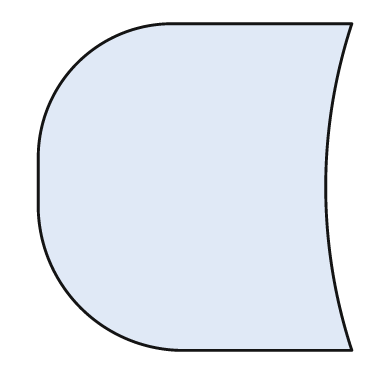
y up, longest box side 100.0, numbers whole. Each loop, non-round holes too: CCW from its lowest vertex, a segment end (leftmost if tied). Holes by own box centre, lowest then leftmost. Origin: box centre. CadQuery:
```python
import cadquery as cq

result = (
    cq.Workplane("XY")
    .moveTo(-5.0, -50.0)
    .lineTo(48.0, -50.0)
    .threePointArc((40.0, 0.0), (48.0, 50.0))
    .lineTo(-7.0, 50.0)
    .threePointArc((-36.0, 38.0), (-48.0, 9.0))
    .lineTo(-48.0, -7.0)
    .threePointArc((-35.0, -37.0), (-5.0, -50.0))
    .close()
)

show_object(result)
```